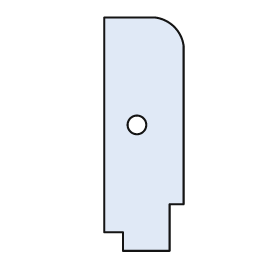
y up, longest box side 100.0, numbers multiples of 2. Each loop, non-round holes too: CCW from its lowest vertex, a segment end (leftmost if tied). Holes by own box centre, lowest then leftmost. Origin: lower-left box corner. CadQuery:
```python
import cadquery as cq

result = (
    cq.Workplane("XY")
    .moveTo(8.0, 0.0)
    .lineTo(28.0, 0.0)
    .lineTo(28.0, 20.0)
    .lineTo(34.0, 20.0)
    .lineTo(34.0, 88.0)
    .threePointArc((30.0, 96.0), (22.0, 100.0))
    .lineTo(0.0, 100.0)
    .lineTo(0.0, 8.0)
    .lineTo(8.0, 8.0)
    .close()
    .moveTo(14.0, 54.0)
    .circle(4.0)
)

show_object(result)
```